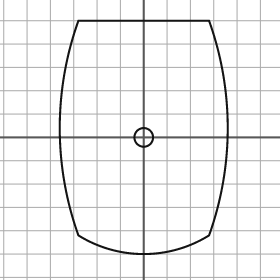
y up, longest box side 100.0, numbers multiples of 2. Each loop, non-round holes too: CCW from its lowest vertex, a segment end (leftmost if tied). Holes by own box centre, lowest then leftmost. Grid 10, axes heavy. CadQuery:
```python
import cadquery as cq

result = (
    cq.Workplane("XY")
    .moveTo(-28.0, -42.0)
    .threePointArc((0.0, -50.0), (28.0, -42.0))
    .threePointArc((36.0, 4.0), (28.0, 50.0))
    .lineTo(-28.0, 50.0)
    .threePointArc((-36.0, 4.0), (-28.0, -42.0))
    .close()
    .moveTo(0.0, 0.0)
    .circle(4.0)
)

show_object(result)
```